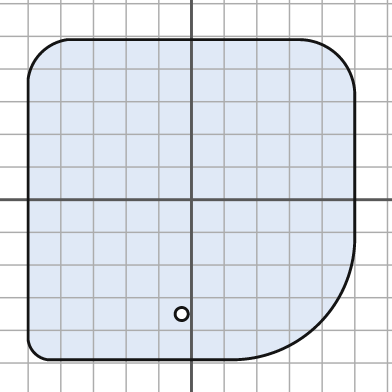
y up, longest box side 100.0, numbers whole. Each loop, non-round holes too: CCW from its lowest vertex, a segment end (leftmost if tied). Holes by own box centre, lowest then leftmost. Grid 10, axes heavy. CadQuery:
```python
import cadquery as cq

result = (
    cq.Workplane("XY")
    .moveTo(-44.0, -49.0)
    .lineTo(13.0, -49.0)
    .threePointArc((39.0, -38.0), (50.0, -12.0))
    .lineTo(50.0, 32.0)
    .threePointArc((45.0, 44.0), (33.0, 49.0))
    .lineTo(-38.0, 49.0)
    .threePointArc((-46.0, 45.0), (-50.0, 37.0))
    .lineTo(-50.0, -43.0)
    .threePointArc((-48.0, -47.0), (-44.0, -49.0))
    .close()
    .moveTo(-3.0, -35.0)
    .circle(2.0)
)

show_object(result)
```